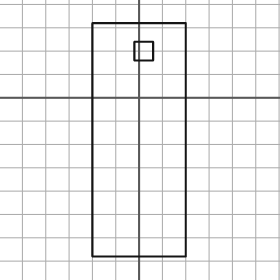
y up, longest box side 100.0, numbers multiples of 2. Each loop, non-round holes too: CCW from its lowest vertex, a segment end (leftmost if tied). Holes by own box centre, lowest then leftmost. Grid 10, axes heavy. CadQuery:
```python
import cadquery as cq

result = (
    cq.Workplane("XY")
    .moveTo(-20.0, -68.0)
    .lineTo(20.0, -68.0)
    .lineTo(20.0, 32.0)
    .lineTo(-20.0, 32.0)
    .close()
    .moveTo(-2.0, 16.0)
    .lineTo(6.0, 16.0)
    .lineTo(6.0, 24.0)
    .lineTo(-2.0, 24.0)
    .close()
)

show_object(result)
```